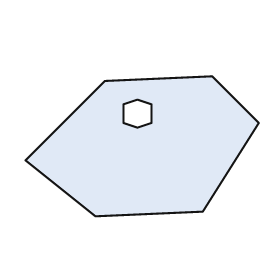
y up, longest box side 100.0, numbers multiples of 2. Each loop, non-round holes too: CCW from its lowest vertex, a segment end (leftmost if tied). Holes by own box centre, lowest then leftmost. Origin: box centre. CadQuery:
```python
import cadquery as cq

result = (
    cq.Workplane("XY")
    .moveTo(-20.0, -30.0)
    .lineTo(26.0, -28.0)
    .lineTo(50.0, 10.0)
    .lineTo(30.0, 30.0)
    .lineTo(-16.0, 28.0)
    .lineTo(-50.0, -6.0)
    .close()
    .moveTo(-2.0, 8.0)
    .lineTo(4.0, 10.0)
    .lineTo(4.0, 18.0)
    .lineTo(-2.0, 20.0)
    .lineTo(-8.0, 18.0)
    .lineTo(-8.0, 10.0)
    .close()
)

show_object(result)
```